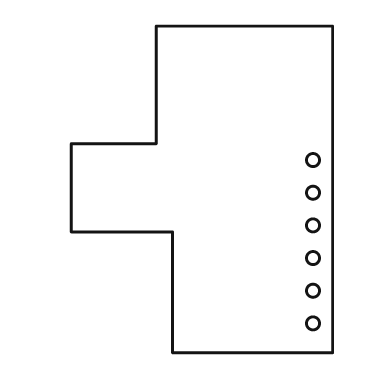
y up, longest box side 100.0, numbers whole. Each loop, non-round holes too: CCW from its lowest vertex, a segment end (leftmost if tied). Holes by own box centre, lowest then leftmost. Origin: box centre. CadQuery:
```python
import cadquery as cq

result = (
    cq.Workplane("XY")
    .moveTo(-9.0, -50.0)
    .lineTo(40.0, -50.0)
    .lineTo(40.0, 50.0)
    .lineTo(-14.0, 50.0)
    .lineTo(-14.0, 14.0)
    .lineTo(-40.0, 14.0)
    .lineTo(-40.0, -13.0)
    .lineTo(-9.0, -13.0)
    .close()
    .moveTo(34.0, -41.0)
    .circle(2.0)
    .moveTo(34.0, -31.0)
    .circle(2.0)
    .moveTo(34.0, -21.0)
    .circle(2.0)
    .moveTo(34.0, -11.0)
    .circle(2.0)
    .moveTo(34.0, -1.0)
    .circle(2.0)
    .moveTo(34.0, 9.0)
    .circle(2.0)
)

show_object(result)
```